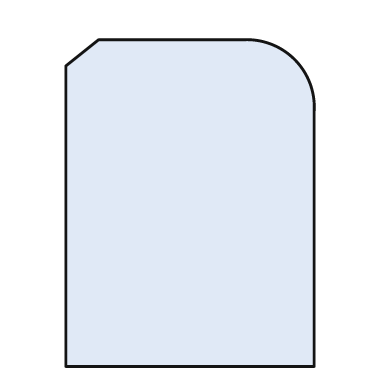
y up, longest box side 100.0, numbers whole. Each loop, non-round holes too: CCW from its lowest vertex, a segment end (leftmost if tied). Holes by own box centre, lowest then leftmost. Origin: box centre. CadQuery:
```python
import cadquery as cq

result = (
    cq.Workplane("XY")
    .moveTo(-38.0, -50.0)
    .lineTo(38.0, -50.0)
    .lineTo(38.0, 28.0)
    .threePointArc((32.0, 44.0), (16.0, 50.0))
    .lineTo(-28.0, 50.0)
    .lineTo(-38.0, 42.0)
    .close()
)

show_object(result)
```